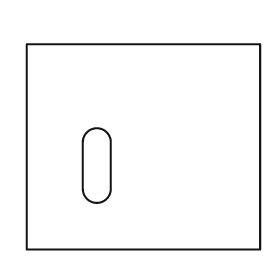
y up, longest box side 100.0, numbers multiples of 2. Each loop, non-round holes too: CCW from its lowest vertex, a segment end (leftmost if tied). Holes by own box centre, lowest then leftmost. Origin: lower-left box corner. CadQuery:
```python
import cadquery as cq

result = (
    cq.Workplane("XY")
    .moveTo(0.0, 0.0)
    .lineTo(100.0, 0.0)
    .lineTo(100.0, 88.0)
    .lineTo(0.0, 88.0)
    .close()
    .moveTo(24.0, 26.0)
    .threePointArc((30.0, 20.0), (36.0, 26.0))
    .lineTo(36.0, 46.0)
    .threePointArc((30.0, 52.0), (24.0, 46.0))
    .close()
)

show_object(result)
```